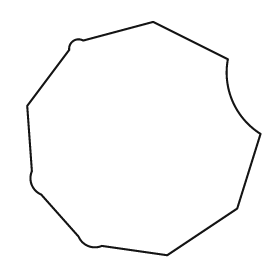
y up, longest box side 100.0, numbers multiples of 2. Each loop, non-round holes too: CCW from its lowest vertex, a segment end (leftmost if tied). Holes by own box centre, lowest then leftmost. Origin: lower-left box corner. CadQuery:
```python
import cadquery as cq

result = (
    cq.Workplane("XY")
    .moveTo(60.0, 0.0)
    .lineTo(90.0, 20.0)
    .lineTo(100.0, 52.0)
    .threePointArc((88.0, 66.0), (86.0, 84.0))
    .lineTo(54.0, 100.0)
    .lineTo(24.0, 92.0)
    .threePointArc((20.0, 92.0), (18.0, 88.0))
    .lineTo(0.0, 64.0)
    .lineTo(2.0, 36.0)
    .threePointArc((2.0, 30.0), (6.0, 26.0))
    .lineTo(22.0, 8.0)
    .threePointArc((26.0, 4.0), (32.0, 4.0))
    .close()
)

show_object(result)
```